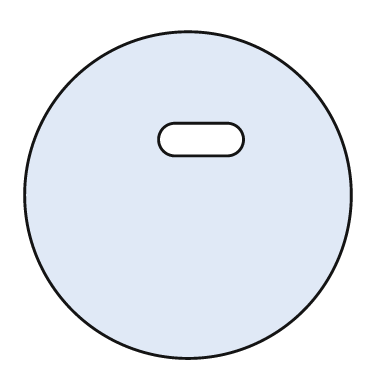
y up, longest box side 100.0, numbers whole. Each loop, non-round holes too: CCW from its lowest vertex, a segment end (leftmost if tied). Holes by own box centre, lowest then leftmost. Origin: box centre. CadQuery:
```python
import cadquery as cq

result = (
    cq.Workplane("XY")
    .moveTo(0.0, 0.0)
    .circle(50.0)
    .moveTo(-4.0, 12.0)
    .lineTo(12.0, 12.0)
    .threePointArc((17.0, 17.0), (12.0, 22.0))
    .lineTo(-4.0, 22.0)
    .threePointArc((-9.0, 17.0), (-4.0, 12.0))
    .close()
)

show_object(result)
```